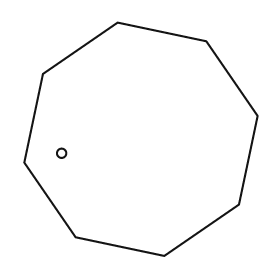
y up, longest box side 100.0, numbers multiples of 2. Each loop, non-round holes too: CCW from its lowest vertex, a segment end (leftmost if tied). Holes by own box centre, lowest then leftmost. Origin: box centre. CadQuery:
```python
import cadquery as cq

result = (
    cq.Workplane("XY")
    .moveTo(10.0, -50.0)
    .lineTo(42.0, -28.0)
    .lineTo(50.0, 10.0)
    .lineTo(28.0, 42.0)
    .lineTo(-10.0, 50.0)
    .lineTo(-42.0, 28.0)
    .lineTo(-50.0, -10.0)
    .lineTo(-28.0, -42.0)
    .close()
    .moveTo(-34.0, -6.0)
    .circle(2.0)
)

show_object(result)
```